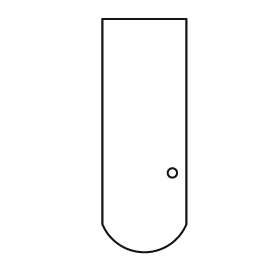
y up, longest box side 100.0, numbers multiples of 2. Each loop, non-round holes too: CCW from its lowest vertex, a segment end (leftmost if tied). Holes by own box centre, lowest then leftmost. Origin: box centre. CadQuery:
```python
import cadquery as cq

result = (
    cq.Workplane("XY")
    .moveTo(-18.0, -38.0)
    .threePointArc((0.0, -50.0), (18.0, -38.0))
    .lineTo(18.0, 50.0)
    .lineTo(-18.0, 50.0)
    .close()
    .moveTo(12.0, -16.0)
    .circle(2.0)
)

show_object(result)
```